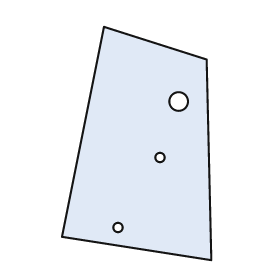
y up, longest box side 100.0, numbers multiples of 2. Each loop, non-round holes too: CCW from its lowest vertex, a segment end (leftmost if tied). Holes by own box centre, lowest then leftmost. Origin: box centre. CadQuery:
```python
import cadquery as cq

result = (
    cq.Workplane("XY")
    .moveTo(32.0, -50.0)
    .lineTo(30.0, 36.0)
    .lineTo(-14.0, 50.0)
    .lineTo(-32.0, -40.0)
    .close()
    .moveTo(-8.0, -36.0)
    .circle(2.0)
    .moveTo(10.0, -6.0)
    .circle(2.0)
    .moveTo(18.0, 18.0)
    .circle(4.0)
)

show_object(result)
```